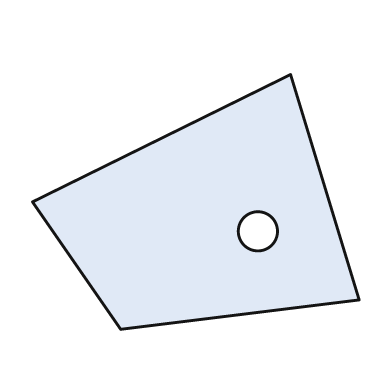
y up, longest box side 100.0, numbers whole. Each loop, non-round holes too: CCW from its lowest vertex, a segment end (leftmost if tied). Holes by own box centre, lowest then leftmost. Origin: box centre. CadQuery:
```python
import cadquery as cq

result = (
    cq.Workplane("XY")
    .moveTo(-23.0, -39.0)
    .lineTo(50.0, -30.0)
    .lineTo(29.0, 39.0)
    .lineTo(-50.0, 0.0)
    .close()
    .moveTo(19.0, -9.0)
    .circle(6.0)
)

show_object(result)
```